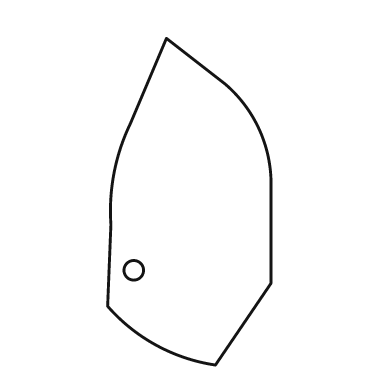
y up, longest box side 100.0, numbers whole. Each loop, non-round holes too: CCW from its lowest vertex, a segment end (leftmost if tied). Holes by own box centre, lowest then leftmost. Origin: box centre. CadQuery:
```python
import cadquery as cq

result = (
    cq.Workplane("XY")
    .moveTo(8.0, -50.0)
    .lineTo(25.0, -25.0)
    .lineTo(25.0, 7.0)
    .threePointArc((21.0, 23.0), (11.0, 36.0))
    .lineTo(-7.0, 50.0)
    .lineTo(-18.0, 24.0)
    .threePointArc((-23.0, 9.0), (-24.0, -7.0))
    .lineTo(-25.0, -32.0)
    .threePointArc((-10.0, -44.0), (8.0, -50.0))
    .close()
    .moveTo(-17.0, -21.0)
    .circle(3.0)
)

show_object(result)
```